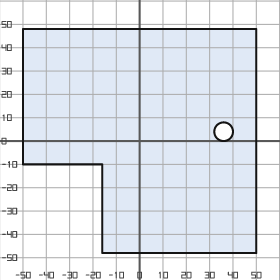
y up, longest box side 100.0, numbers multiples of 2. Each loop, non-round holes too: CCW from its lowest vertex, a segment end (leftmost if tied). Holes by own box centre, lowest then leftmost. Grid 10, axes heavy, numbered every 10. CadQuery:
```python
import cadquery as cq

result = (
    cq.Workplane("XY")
    .moveTo(-16.0, -48.0)
    .lineTo(50.0, -48.0)
    .lineTo(50.0, 48.0)
    .lineTo(-50.0, 48.0)
    .lineTo(-50.0, -10.0)
    .lineTo(-16.0, -10.0)
    .close()
    .moveTo(36.0, 4.0)
    .circle(4.0)
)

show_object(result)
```